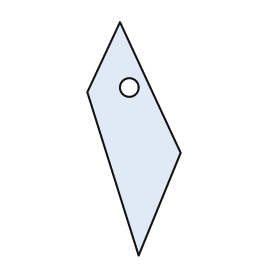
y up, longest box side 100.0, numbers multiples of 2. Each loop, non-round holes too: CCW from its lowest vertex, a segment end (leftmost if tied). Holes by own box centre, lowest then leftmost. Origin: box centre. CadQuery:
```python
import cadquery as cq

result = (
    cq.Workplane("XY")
    .moveTo(2.0, -50.0)
    .lineTo(20.0, -6.0)
    .lineTo(-6.0, 50.0)
    .lineTo(-20.0, 20.0)
    .close()
    .moveTo(-2.0, 22.0)
    .circle(4.0)
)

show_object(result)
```